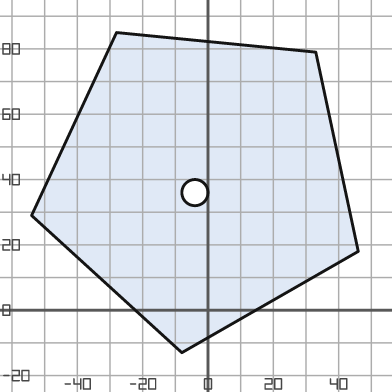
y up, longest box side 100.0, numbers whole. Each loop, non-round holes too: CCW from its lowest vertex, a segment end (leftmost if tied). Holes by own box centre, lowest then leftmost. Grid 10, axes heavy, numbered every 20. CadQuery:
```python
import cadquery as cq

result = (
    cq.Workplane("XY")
    .moveTo(-8.0, -13.0)
    .lineTo(46.0, 18.0)
    .lineTo(33.0, 79.0)
    .lineTo(-28.0, 85.0)
    .lineTo(-54.0, 29.0)
    .close()
    .moveTo(-4.0, 36.0)
    .circle(4.0)
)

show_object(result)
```